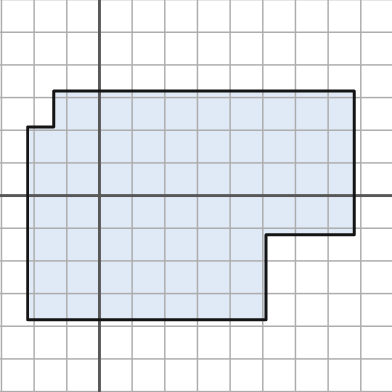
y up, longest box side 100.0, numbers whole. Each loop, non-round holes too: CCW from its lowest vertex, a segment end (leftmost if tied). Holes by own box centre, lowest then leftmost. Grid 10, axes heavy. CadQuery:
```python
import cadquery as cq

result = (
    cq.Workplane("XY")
    .moveTo(-22.0, -38.0)
    .lineTo(51.0, -38.0)
    .lineTo(51.0, -12.0)
    .lineTo(78.0, -12.0)
    .lineTo(78.0, 32.0)
    .lineTo(-14.0, 32.0)
    .lineTo(-14.0, 21.0)
    .lineTo(-22.0, 21.0)
    .close()
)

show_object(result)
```